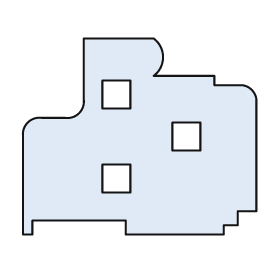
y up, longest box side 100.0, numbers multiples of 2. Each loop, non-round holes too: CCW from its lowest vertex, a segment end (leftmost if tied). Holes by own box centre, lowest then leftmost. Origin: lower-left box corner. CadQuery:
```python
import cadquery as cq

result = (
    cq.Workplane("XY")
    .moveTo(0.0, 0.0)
    .lineTo(4.0, 0.0)
    .lineTo(4.0, 6.0)
    .lineTo(44.0, 6.0)
    .lineTo(44.0, 0.0)
    .lineTo(86.0, 0.0)
    .lineTo(86.0, 4.0)
    .lineTo(92.0, 4.0)
    .lineTo(92.0, 10.0)
    .lineTo(100.0, 10.0)
    .lineTo(100.0, 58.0)
    .threePointArc((98.0, 62.0), (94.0, 64.0))
    .lineTo(82.0, 64.0)
    .lineTo(82.0, 68.0)
    .lineTo(56.0, 68.0)
    .threePointArc((60.0, 76.0), (56.0, 84.0))
    .lineTo(26.0, 84.0)
    .lineTo(26.0, 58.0)
    .threePointArc((24.0, 52.0), (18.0, 50.0))
    .lineTo(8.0, 50.0)
    .threePointArc((2.0, 48.0), (0.0, 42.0))
    .close()
    .moveTo(34.0, 18.0)
    .lineTo(46.0, 18.0)
    .lineTo(46.0, 30.0)
    .lineTo(34.0, 30.0)
    .close()
    .moveTo(64.0, 36.0)
    .lineTo(76.0, 36.0)
    .lineTo(76.0, 48.0)
    .lineTo(64.0, 48.0)
    .close()
    .moveTo(34.0, 54.0)
    .lineTo(46.0, 54.0)
    .lineTo(46.0, 66.0)
    .lineTo(34.0, 66.0)
    .close()
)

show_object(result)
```